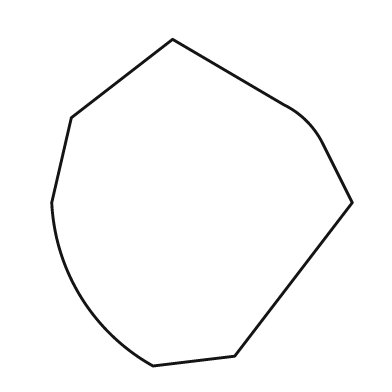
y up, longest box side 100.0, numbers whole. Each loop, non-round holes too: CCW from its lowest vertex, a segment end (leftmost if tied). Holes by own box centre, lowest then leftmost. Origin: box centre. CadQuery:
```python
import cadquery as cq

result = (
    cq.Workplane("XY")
    .moveTo(-15.0, -50.0)
    .lineTo(10.0, -47.0)
    .lineTo(46.0, 0.0)
    .lineTo(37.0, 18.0)
    .threePointArc((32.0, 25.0), (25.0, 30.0))
    .lineTo(-9.0, 50.0)
    .lineTo(-40.0, 26.0)
    .lineTo(-46.0, 0.0)
    .threePointArc((-37.0, -29.0), (-15.0, -50.0))
    .close()
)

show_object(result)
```